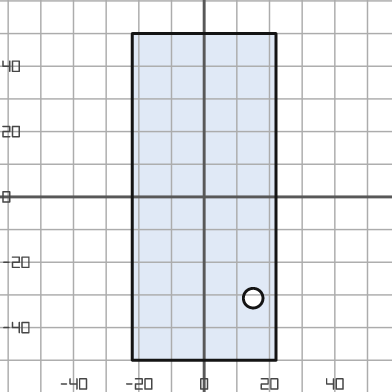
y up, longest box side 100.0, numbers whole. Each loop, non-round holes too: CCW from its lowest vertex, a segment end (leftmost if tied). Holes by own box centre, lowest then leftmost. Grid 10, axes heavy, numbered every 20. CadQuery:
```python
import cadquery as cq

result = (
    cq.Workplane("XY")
    .moveTo(-22.0, -50.0)
    .lineTo(22.0, -50.0)
    .lineTo(22.0, 50.0)
    .lineTo(-22.0, 50.0)
    .close()
    .moveTo(15.0, -31.0)
    .circle(3.0)
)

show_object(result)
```